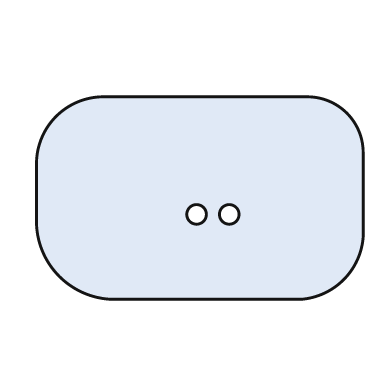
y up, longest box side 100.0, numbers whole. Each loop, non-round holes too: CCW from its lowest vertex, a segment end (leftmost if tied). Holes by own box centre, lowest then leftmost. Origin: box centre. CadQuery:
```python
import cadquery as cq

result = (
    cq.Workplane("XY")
    .moveTo(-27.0, -31.0)
    .lineTo(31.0, -31.0)
    .threePointArc((44.0, -25.0), (50.0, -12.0))
    .lineTo(50.0, 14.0)
    .threePointArc((45.0, 26.0), (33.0, 31.0))
    .lineTo(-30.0, 31.0)
    .threePointArc((-44.0, 25.0), (-50.0, 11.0))
    .lineTo(-50.0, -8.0)
    .threePointArc((-43.0, -24.0), (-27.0, -31.0))
    .close()
    .moveTo(-1.0, -5.0)
    .circle(3.0)
    .moveTo(9.0, -5.0)
    .circle(3.0)
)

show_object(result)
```